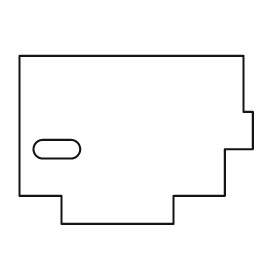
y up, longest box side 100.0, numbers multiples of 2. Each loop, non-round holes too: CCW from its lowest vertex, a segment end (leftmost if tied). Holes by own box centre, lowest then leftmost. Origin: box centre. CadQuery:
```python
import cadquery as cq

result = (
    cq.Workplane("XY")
    .moveTo(-32.0, -36.0)
    .lineTo(16.0, -36.0)
    .lineTo(16.0, -24.0)
    .lineTo(38.0, -24.0)
    .lineTo(38.0, -4.0)
    .lineTo(50.0, -4.0)
    .lineTo(50.0, 12.0)
    .lineTo(46.0, 12.0)
    .lineTo(46.0, 36.0)
    .lineTo(-50.0, 36.0)
    .lineTo(-50.0, -24.0)
    .lineTo(-32.0, -24.0)
    .close()
    .moveTo(-40.0, -8.0)
    .lineTo(-28.0, -8.0)
    .threePointArc((-24.0, -4.0), (-28.0, 0.0))
    .lineTo(-40.0, 0.0)
    .threePointArc((-44.0, -4.0), (-40.0, -8.0))
    .close()
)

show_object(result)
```